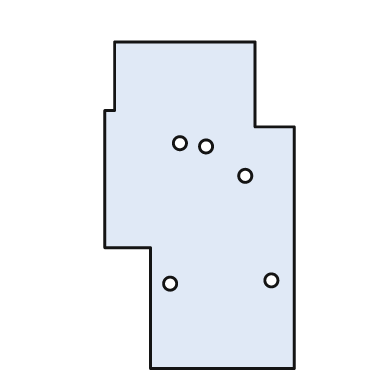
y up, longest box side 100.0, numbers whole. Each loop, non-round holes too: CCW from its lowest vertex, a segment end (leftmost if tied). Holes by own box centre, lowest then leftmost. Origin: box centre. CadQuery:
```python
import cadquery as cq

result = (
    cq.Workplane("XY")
    .moveTo(-15.0, -50.0)
    .lineTo(29.0, -50.0)
    .lineTo(29.0, 24.0)
    .lineTo(17.0, 24.0)
    .lineTo(17.0, 50.0)
    .lineTo(-26.0, 50.0)
    .lineTo(-26.0, 29.0)
    .lineTo(-29.0, 29.0)
    .lineTo(-29.0, -13.0)
    .lineTo(-15.0, -13.0)
    .close()
    .moveTo(-9.0, -24.0)
    .circle(2.0)
    .moveTo(22.0, -23.0)
    .circle(2.0)
    .moveTo(14.0, 9.0)
    .circle(2.0)
    .moveTo(2.0, 18.0)
    .circle(2.0)
    .moveTo(-6.0, 19.0)
    .circle(2.0)
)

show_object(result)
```